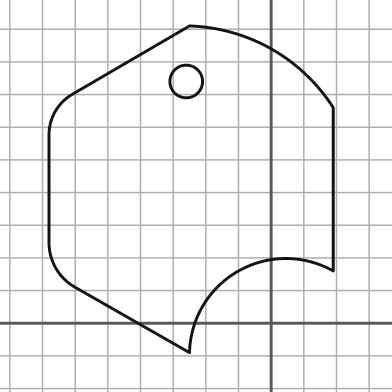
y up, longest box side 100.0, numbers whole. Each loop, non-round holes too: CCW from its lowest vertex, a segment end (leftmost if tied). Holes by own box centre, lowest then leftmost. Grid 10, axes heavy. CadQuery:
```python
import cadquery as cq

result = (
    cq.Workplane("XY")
    .moveTo(-25.0, -9.0)
    .threePointArc((-10.0, 16.0), (19.0, 16.0))
    .lineTo(19.0, 66.0)
    .threePointArc((0.0, 84.0), (-25.0, 91.0))
    .lineTo(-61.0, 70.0)
    .threePointArc((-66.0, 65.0), (-68.0, 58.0))
    .lineTo(-68.0, 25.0)
    .threePointArc((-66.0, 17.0), (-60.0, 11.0))
    .close()
    .moveTo(-26.0, 74.0)
    .circle(5.0)
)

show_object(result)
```